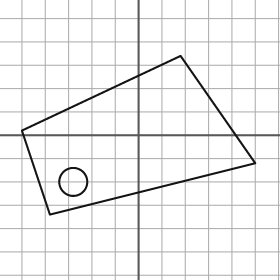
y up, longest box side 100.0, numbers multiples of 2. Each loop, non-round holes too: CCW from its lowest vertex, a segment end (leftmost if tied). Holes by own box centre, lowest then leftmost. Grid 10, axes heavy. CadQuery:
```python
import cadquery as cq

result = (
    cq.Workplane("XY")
    .moveTo(-38.0, -34.0)
    .lineTo(50.0, -12.0)
    .lineTo(18.0, 34.0)
    .lineTo(-50.0, 2.0)
    .close()
    .moveTo(-28.0, -20.0)
    .circle(6.0)
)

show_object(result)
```